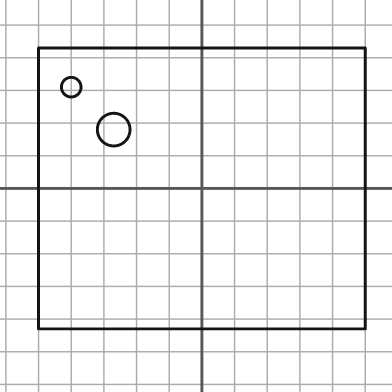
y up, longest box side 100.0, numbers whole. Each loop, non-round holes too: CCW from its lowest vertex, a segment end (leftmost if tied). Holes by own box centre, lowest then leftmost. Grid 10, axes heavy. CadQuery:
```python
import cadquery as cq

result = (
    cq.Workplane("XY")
    .moveTo(-50.0, -43.0)
    .lineTo(50.0, -43.0)
    .lineTo(50.0, 43.0)
    .lineTo(-50.0, 43.0)
    .close()
    .moveTo(-27.0, 18.0)
    .circle(5.0)
    .moveTo(-40.0, 31.0)
    .circle(3.0)
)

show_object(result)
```